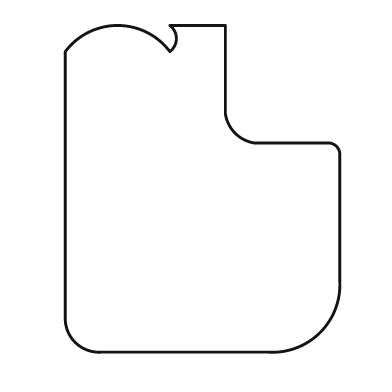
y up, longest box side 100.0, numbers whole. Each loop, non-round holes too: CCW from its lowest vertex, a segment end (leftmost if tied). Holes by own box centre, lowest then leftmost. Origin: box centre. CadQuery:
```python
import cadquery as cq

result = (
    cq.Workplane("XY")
    .moveTo(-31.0, -50.0)
    .lineTo(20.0, -50.0)
    .threePointArc((36.0, -44.0), (42.0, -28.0))
    .lineTo(42.0, 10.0)
    .threePointArc((41.0, 13.0), (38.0, 14.0))
    .lineTo(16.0, 14.0)
    .threePointArc((10.0, 17.0), (7.0, 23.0))
    .lineTo(7.0, 50.0)
    .lineTo(-10.0, 50.0)
    .threePointArc((-8.0, 46.0), (-10.0, 42.0))
    .threePointArc((-26.0, 50.0), (-42.0, 42.0))
    .lineTo(-42.0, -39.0)
    .threePointArc((-39.0, -47.0), (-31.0, -50.0))
    .close()
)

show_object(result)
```